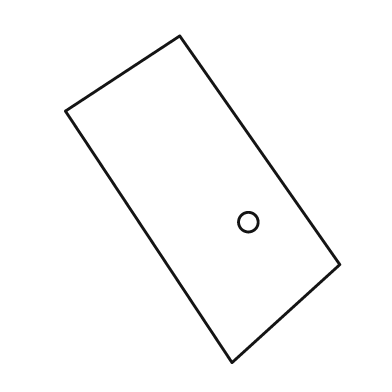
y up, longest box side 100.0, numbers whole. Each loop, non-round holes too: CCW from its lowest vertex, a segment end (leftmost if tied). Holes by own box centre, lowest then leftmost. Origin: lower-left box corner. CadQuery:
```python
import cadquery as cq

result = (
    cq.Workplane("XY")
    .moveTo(51.0, 0.0)
    .lineTo(84.0, 30.0)
    .lineTo(35.0, 100.0)
    .lineTo(0.0, 77.0)
    .close()
    .moveTo(56.0, 43.0)
    .circle(3.0)
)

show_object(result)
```